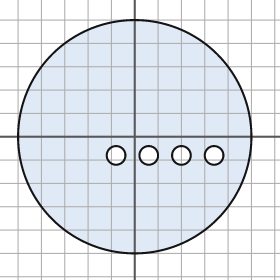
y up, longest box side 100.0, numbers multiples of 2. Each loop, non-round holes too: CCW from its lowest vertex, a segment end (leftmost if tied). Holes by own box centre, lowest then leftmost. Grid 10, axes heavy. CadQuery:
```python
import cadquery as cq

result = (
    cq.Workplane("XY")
    .moveTo(0.0, 0.0)
    .circle(50.0)
    .moveTo(-8.0, -8.0)
    .circle(4.0)
    .moveTo(6.0, -8.0)
    .circle(4.0)
    .moveTo(20.0, -8.0)
    .circle(4.0)
    .moveTo(34.0, -8.0)
    .circle(4.0)
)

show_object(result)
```